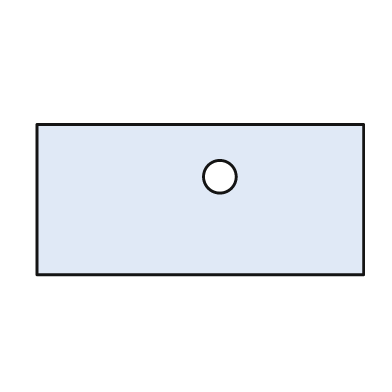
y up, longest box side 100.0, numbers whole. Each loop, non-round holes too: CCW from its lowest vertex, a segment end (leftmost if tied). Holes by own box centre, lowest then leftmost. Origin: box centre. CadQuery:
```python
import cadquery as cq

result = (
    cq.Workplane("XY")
    .moveTo(-50.0, -23.0)
    .lineTo(50.0, -23.0)
    .lineTo(50.0, 23.0)
    .lineTo(-50.0, 23.0)
    .close()
    .moveTo(6.0, 7.0)
    .circle(5.0)
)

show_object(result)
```